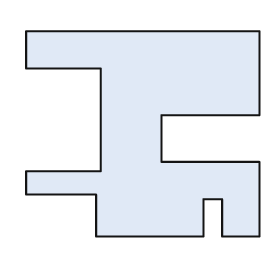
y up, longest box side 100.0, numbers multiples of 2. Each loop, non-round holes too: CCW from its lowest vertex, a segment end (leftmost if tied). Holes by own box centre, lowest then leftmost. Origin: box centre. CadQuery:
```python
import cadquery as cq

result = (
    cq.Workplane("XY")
    .moveTo(-20.0, -44.0)
    .lineTo(26.0, -44.0)
    .lineTo(26.0, -28.0)
    .lineTo(34.0, -28.0)
    .lineTo(34.0, -44.0)
    .lineTo(50.0, -44.0)
    .lineTo(50.0, -12.0)
    .lineTo(8.0, -12.0)
    .lineTo(8.0, 8.0)
    .lineTo(50.0, 8.0)
    .lineTo(50.0, 44.0)
    .lineTo(-50.0, 44.0)
    .lineTo(-50.0, 28.0)
    .lineTo(-18.0, 28.0)
    .lineTo(-18.0, -16.0)
    .lineTo(-50.0, -16.0)
    .lineTo(-50.0, -26.0)
    .lineTo(-20.0, -26.0)
    .close()
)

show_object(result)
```